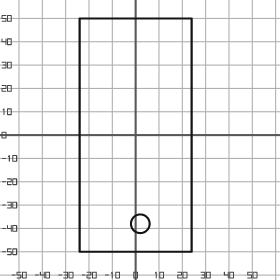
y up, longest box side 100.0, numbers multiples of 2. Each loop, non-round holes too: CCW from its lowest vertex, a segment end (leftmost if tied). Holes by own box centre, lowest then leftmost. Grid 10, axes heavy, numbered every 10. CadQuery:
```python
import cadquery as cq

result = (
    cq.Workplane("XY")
    .moveTo(-24.0, -50.0)
    .lineTo(24.0, -50.0)
    .lineTo(24.0, 50.0)
    .lineTo(-24.0, 50.0)
    .close()
    .moveTo(2.0, -38.0)
    .circle(4.0)
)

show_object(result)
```